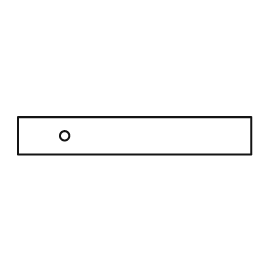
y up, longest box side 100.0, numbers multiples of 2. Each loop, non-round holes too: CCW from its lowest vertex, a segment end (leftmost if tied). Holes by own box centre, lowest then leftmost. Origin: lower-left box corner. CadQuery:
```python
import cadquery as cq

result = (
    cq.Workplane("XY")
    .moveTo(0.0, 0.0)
    .lineTo(100.0, 0.0)
    .lineTo(100.0, 16.0)
    .lineTo(0.0, 16.0)
    .close()
    .moveTo(20.0, 8.0)
    .circle(2.0)
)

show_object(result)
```